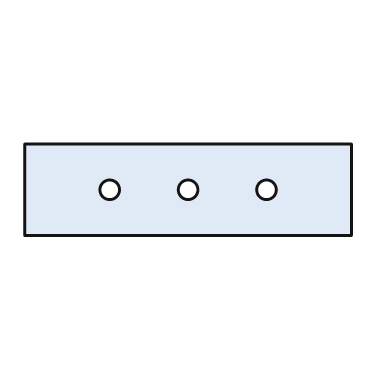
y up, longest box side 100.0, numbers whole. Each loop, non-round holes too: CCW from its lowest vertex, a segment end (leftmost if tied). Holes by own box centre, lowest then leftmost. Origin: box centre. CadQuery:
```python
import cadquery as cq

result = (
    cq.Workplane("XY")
    .moveTo(-50.0, -14.0)
    .lineTo(50.0, -14.0)
    .lineTo(50.0, 14.0)
    .lineTo(-50.0, 14.0)
    .close()
    .moveTo(-24.0, 0.0)
    .circle(3.0)
    .moveTo(0.0, 0.0)
    .circle(3.0)
    .moveTo(24.0, 0.0)
    .circle(3.0)
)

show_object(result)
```